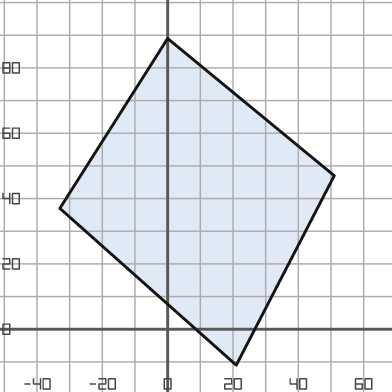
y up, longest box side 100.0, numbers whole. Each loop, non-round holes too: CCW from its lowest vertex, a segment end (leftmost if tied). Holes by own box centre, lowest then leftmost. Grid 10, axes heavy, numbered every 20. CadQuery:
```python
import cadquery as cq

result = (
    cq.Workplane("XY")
    .moveTo(21.0, -11.0)
    .lineTo(51.0, 47.0)
    .lineTo(0.0, 89.0)
    .lineTo(-33.0, 37.0)
    .close()
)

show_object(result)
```